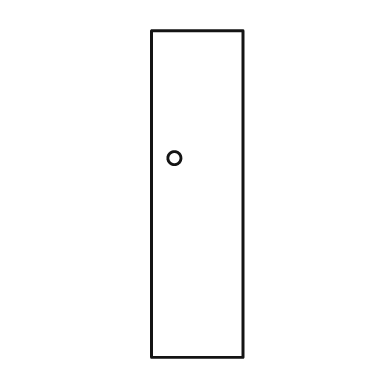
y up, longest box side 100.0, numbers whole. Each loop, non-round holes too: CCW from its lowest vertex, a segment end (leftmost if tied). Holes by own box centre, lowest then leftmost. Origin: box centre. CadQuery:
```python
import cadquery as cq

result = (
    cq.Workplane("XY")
    .moveTo(-14.0, -50.0)
    .lineTo(14.0, -50.0)
    .lineTo(14.0, 50.0)
    .lineTo(-14.0, 50.0)
    .close()
    .moveTo(-7.0, 11.0)
    .circle(2.0)
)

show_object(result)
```